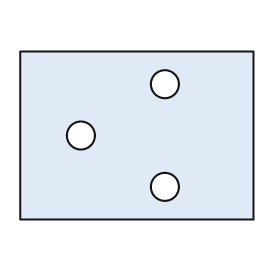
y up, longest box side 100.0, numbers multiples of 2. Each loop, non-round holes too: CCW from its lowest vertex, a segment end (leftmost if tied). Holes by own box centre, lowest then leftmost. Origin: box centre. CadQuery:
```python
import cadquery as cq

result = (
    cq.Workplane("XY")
    .moveTo(-50.0, -36.0)
    .lineTo(50.0, -36.0)
    .lineTo(50.0, 36.0)
    .lineTo(-50.0, 36.0)
    .close()
    .moveTo(12.0, -22.0)
    .circle(6.0)
    .moveTo(-24.0, 0.0)
    .circle(6.0)
    .moveTo(12.0, 22.0)
    .circle(6.0)
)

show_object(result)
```